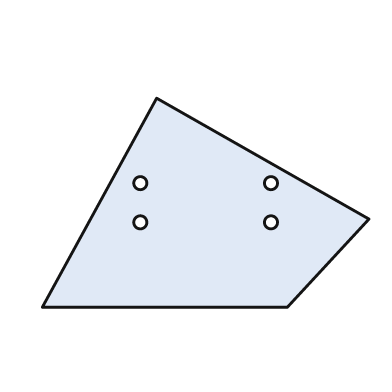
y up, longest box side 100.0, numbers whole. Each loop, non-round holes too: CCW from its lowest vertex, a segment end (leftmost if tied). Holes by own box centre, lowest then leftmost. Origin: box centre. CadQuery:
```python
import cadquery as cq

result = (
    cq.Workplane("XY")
    .moveTo(-50.0, -32.0)
    .lineTo(25.0, -32.0)
    .lineTo(50.0, -5.0)
    .lineTo(-15.0, 32.0)
    .close()
    .moveTo(-20.0, -6.0)
    .circle(2.0)
    .moveTo(20.0, -6.0)
    .circle(2.0)
    .moveTo(-20.0, 6.0)
    .circle(2.0)
    .moveTo(20.0, 6.0)
    .circle(2.0)
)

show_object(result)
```